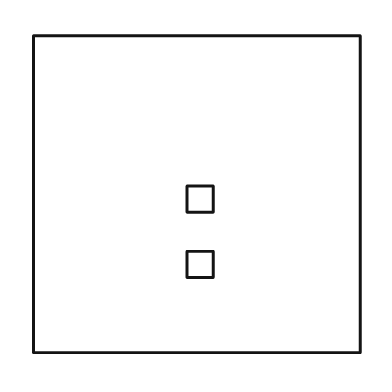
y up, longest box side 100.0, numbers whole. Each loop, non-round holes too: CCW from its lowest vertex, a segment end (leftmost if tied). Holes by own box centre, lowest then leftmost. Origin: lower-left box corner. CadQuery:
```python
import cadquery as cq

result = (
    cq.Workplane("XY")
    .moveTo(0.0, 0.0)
    .lineTo(100.0, 0.0)
    .lineTo(100.0, 97.0)
    .lineTo(0.0, 97.0)
    .close()
    .moveTo(47.0, 23.0)
    .lineTo(55.0, 23.0)
    .lineTo(55.0, 31.0)
    .lineTo(47.0, 31.0)
    .close()
    .moveTo(47.0, 43.0)
    .lineTo(55.0, 43.0)
    .lineTo(55.0, 51.0)
    .lineTo(47.0, 51.0)
    .close()
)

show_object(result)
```